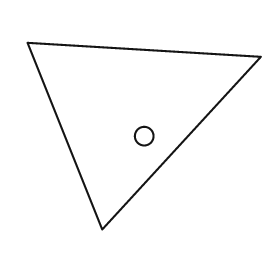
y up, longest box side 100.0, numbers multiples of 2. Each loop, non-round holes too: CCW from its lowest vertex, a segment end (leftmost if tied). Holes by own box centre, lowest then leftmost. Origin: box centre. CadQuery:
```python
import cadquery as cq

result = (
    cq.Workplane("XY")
    .moveTo(-18.0, -40.0)
    .lineTo(50.0, 34.0)
    .lineTo(-50.0, 40.0)
    .close()
    .moveTo(0.0, 0.0)
    .circle(4.0)
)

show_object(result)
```